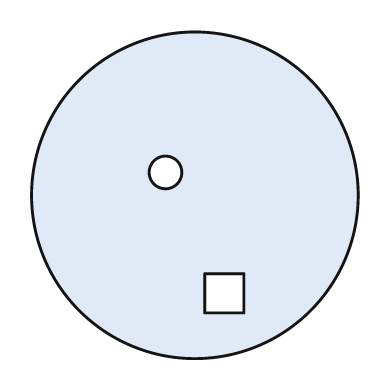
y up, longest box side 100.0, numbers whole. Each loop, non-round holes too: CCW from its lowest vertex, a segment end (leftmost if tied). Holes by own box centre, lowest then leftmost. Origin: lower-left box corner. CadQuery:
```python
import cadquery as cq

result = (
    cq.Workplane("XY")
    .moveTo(50.0, 50.0)
    .circle(50.0)
    .moveTo(53.0, 14.0)
    .lineTo(65.0, 14.0)
    .lineTo(65.0, 26.0)
    .lineTo(53.0, 26.0)
    .close()
    .moveTo(41.0, 57.0)
    .circle(5.0)
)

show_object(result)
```